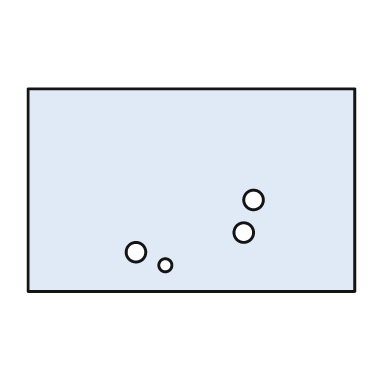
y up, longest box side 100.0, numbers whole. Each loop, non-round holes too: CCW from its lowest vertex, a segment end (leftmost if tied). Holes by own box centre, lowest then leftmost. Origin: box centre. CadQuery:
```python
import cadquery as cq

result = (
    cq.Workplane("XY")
    .moveTo(-50.0, -31.0)
    .lineTo(50.0, -31.0)
    .lineTo(50.0, 31.0)
    .lineTo(-50.0, 31.0)
    .close()
    .moveTo(-8.0, -23.0)
    .circle(2.0)
    .moveTo(-17.0, -19.0)
    .circle(3.0)
    .moveTo(16.0, -13.0)
    .circle(3.0)
    .moveTo(19.0, -3.0)
    .circle(3.0)
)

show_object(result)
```